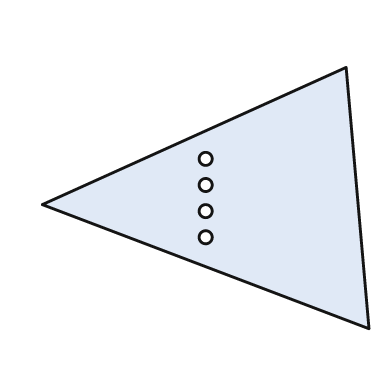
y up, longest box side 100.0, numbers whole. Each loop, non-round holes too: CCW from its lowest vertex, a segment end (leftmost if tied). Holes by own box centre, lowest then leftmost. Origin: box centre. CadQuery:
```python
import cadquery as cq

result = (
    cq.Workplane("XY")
    .moveTo(50.0, -40.0)
    .lineTo(43.0, 40.0)
    .lineTo(-50.0, -2.0)
    .close()
    .moveTo(0.0, -12.0)
    .circle(2.0)
    .moveTo(0.0, -4.0)
    .circle(2.0)
    .moveTo(0.0, 4.0)
    .circle(2.0)
    .moveTo(0.0, 12.0)
    .circle(2.0)
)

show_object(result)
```